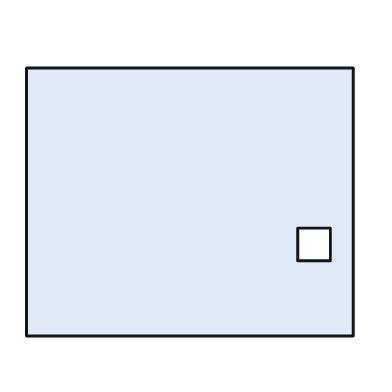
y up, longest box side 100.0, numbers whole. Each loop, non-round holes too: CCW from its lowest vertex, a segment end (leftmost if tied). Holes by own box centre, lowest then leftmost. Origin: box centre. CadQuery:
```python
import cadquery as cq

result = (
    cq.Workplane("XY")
    .moveTo(-50.0, -41.0)
    .lineTo(50.0, -41.0)
    .lineTo(50.0, 41.0)
    .lineTo(-50.0, 41.0)
    .close()
    .moveTo(33.0, -18.0)
    .lineTo(43.0, -18.0)
    .lineTo(43.0, -8.0)
    .lineTo(33.0, -8.0)
    .close()
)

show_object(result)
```